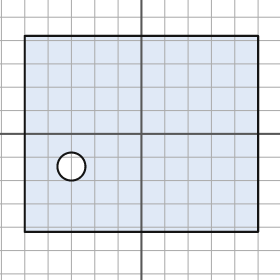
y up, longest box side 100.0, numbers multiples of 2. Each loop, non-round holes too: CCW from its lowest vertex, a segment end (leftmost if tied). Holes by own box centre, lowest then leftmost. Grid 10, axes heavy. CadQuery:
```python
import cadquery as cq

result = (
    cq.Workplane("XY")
    .moveTo(-50.0, -42.0)
    .lineTo(50.0, -42.0)
    .lineTo(50.0, 42.0)
    .lineTo(-50.0, 42.0)
    .close()
    .moveTo(-30.0, -14.0)
    .circle(6.0)
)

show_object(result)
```